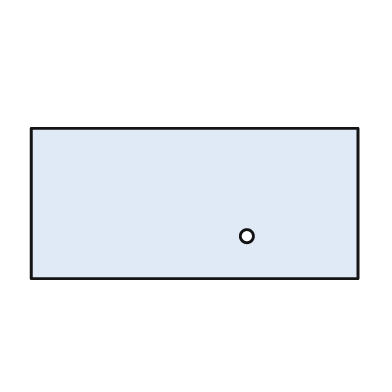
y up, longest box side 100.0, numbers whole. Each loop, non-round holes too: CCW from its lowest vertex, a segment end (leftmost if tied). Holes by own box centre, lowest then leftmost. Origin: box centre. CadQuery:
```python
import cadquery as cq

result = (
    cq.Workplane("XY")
    .moveTo(-50.0, -23.0)
    .lineTo(50.0, -23.0)
    .lineTo(50.0, 23.0)
    .lineTo(-50.0, 23.0)
    .close()
    .moveTo(16.0, -10.0)
    .circle(2.0)
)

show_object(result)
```